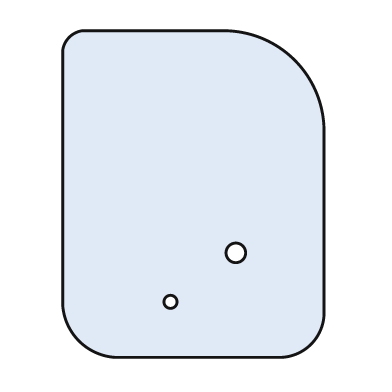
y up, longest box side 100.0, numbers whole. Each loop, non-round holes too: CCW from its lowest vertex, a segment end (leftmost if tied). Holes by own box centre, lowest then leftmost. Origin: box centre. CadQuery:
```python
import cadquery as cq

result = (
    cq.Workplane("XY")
    .moveTo(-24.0, -50.0)
    .lineTo(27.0, -50.0)
    .threePointArc((36.0, -46.0), (40.0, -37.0))
    .lineTo(40.0, 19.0)
    .threePointArc((31.0, 41.0), (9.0, 50.0))
    .lineTo(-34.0, 50.0)
    .threePointArc((-38.0, 48.0), (-40.0, 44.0))
    .lineTo(-40.0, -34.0)
    .threePointArc((-35.0, -45.0), (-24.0, -50.0))
    .close()
    .moveTo(-7.0, -33.0)
    .circle(2.0)
    .moveTo(13.0, -18.0)
    .circle(3.0)
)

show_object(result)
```